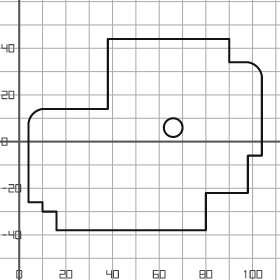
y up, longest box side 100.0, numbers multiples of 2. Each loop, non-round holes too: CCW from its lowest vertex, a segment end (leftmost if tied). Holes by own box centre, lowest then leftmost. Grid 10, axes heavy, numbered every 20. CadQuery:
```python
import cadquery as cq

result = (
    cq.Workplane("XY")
    .moveTo(16.0, -38.0)
    .lineTo(80.0, -38.0)
    .lineTo(80.0, -22.0)
    .lineTo(98.0, -22.0)
    .lineTo(98.0, -6.0)
    .lineTo(104.0, -6.0)
    .lineTo(104.0, 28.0)
    .threePointArc((102.0, 32.0), (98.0, 34.0))
    .lineTo(90.0, 34.0)
    .lineTo(90.0, 44.0)
    .lineTo(38.0, 44.0)
    .lineTo(38.0, 14.0)
    .lineTo(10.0, 14.0)
    .threePointArc((6.0, 12.0), (4.0, 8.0))
    .lineTo(4.0, -26.0)
    .lineTo(10.0, -26.0)
    .lineTo(10.0, -30.0)
    .lineTo(16.0, -30.0)
    .close()
    .moveTo(66.0, 6.0)
    .circle(4.0)
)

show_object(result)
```